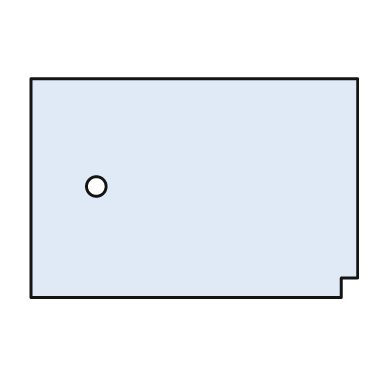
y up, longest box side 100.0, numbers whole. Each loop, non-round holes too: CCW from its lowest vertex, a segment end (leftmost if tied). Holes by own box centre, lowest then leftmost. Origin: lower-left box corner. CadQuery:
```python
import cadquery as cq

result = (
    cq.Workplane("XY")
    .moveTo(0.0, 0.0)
    .lineTo(95.0, 0.0)
    .lineTo(95.0, 6.0)
    .lineTo(100.0, 6.0)
    .lineTo(100.0, 67.0)
    .lineTo(0.0, 67.0)
    .close()
    .moveTo(20.0, 34.0)
    .circle(3.0)
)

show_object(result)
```